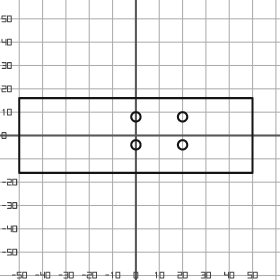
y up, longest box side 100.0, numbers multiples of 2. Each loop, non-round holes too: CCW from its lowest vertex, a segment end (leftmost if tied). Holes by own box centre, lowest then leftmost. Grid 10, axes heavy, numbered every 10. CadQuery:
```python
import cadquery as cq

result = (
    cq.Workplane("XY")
    .moveTo(-50.0, -16.0)
    .lineTo(50.0, -16.0)
    .lineTo(50.0, 16.0)
    .lineTo(-50.0, 16.0)
    .close()
    .moveTo(0.0, -4.0)
    .circle(2.0)
    .moveTo(20.0, -4.0)
    .circle(2.0)
    .moveTo(0.0, 8.0)
    .circle(2.0)
    .moveTo(20.0, 8.0)
    .circle(2.0)
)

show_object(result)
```